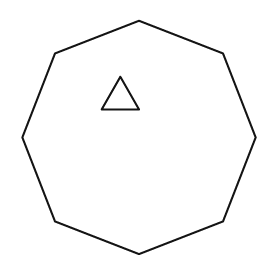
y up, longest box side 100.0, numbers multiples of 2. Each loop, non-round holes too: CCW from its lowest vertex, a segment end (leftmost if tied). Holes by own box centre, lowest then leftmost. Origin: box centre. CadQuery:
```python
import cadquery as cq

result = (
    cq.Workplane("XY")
    .moveTo(0.0, -50.0)
    .lineTo(36.0, -36.0)
    .lineTo(50.0, 0.0)
    .lineTo(36.0, 36.0)
    .lineTo(0.0, 50.0)
    .lineTo(-36.0, 36.0)
    .lineTo(-50.0, 0.0)
    .lineTo(-36.0, -36.0)
    .close()
    .moveTo(-16.0, 12.0)
    .lineTo(0.0, 12.0)
    .lineTo(-8.0, 26.0)
    .close()
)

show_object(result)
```